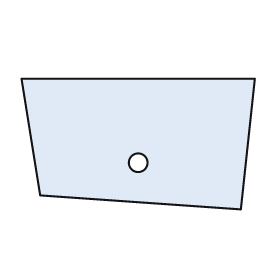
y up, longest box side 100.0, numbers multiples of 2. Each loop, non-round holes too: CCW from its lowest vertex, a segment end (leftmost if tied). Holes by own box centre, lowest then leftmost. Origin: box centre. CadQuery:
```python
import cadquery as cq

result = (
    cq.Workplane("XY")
    .moveTo(44.0, -28.0)
    .lineTo(50.0, 28.0)
    .lineTo(-50.0, 28.0)
    .lineTo(-42.0, -22.0)
    .close()
    .moveTo(0.0, -8.0)
    .circle(4.0)
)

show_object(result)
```